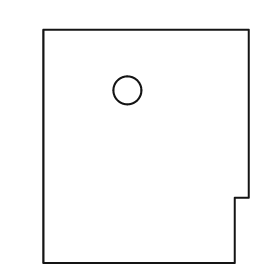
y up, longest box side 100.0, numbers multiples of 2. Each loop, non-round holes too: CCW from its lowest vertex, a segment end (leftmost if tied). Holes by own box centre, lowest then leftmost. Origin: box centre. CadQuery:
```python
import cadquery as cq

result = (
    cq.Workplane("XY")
    .moveTo(-44.0, -50.0)
    .lineTo(38.0, -50.0)
    .lineTo(38.0, -22.0)
    .lineTo(44.0, -22.0)
    .lineTo(44.0, 50.0)
    .lineTo(-44.0, 50.0)
    .close()
    .moveTo(-8.0, 24.0)
    .circle(6.0)
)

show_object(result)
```